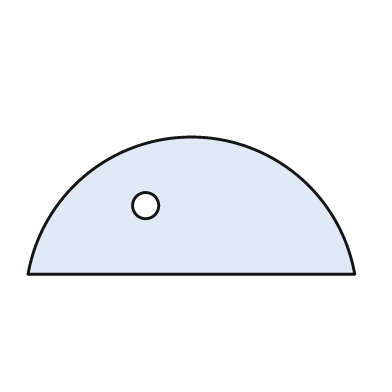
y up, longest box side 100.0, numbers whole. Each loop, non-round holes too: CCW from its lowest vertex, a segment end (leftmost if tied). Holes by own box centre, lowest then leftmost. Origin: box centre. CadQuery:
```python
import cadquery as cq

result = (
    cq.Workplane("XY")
    .moveTo(-50.0, -21.0)
    .lineTo(50.0, -21.0)
    .threePointArc((0.0, 21.0), (-50.0, -21.0))
    .close()
    .moveTo(-14.0, 0.0)
    .circle(4.0)
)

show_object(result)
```